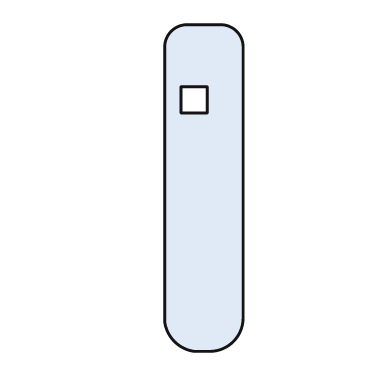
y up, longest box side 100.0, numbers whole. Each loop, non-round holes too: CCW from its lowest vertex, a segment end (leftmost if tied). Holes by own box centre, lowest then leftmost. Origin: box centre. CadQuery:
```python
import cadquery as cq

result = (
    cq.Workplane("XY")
    .moveTo(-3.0, -50.0)
    .lineTo(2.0, -50.0)
    .threePointArc((9.0, -47.0), (12.0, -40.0))
    .lineTo(12.0, 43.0)
    .threePointArc((10.0, 48.0), (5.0, 50.0))
    .lineTo(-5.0, 50.0)
    .threePointArc((-10.0, 48.0), (-12.0, 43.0))
    .lineTo(-12.0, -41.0)
    .threePointArc((-9.0, -47.0), (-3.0, -50.0))
    .close()
    .moveTo(-7.0, 23.0)
    .lineTo(1.0, 23.0)
    .lineTo(1.0, 31.0)
    .lineTo(-7.0, 31.0)
    .close()
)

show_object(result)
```